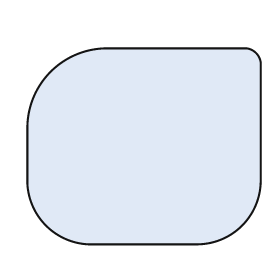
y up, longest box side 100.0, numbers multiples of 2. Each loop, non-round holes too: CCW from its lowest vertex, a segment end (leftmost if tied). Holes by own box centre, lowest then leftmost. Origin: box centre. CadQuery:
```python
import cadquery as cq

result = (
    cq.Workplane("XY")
    .moveTo(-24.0, -42.0)
    .lineTo(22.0, -42.0)
    .threePointArc((42.0, -34.0), (50.0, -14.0))
    .lineTo(50.0, 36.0)
    .threePointArc((48.0, 40.0), (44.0, 42.0))
    .lineTo(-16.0, 42.0)
    .threePointArc((-40.0, 32.0), (-50.0, 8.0))
    .lineTo(-50.0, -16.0)
    .threePointArc((-42.0, -34.0), (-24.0, -42.0))
    .close()
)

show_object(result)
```